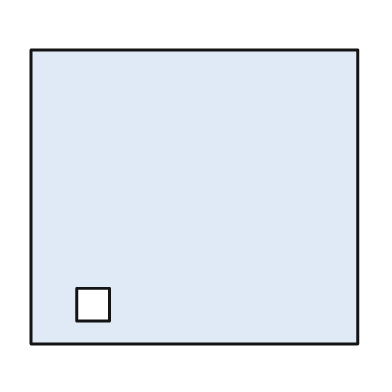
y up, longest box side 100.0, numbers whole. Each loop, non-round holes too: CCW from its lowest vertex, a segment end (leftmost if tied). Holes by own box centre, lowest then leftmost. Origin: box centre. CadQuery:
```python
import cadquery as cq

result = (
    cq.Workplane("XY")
    .moveTo(-50.0, -45.0)
    .lineTo(50.0, -45.0)
    .lineTo(50.0, 45.0)
    .lineTo(-50.0, 45.0)
    .close()
    .moveTo(-36.0, -38.0)
    .lineTo(-26.0, -38.0)
    .lineTo(-26.0, -28.0)
    .lineTo(-36.0, -28.0)
    .close()
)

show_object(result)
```